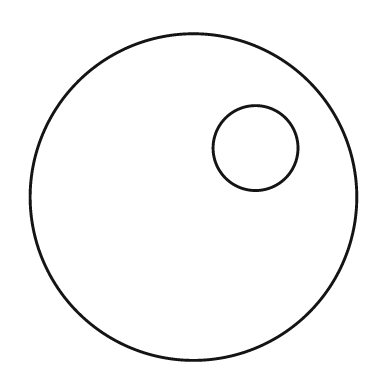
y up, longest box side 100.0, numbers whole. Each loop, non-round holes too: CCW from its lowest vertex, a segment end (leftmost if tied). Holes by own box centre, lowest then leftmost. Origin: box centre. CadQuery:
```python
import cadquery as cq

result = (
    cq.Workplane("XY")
    .moveTo(0.0, 0.0)
    .circle(50.0)
    .moveTo(19.0, 15.0)
    .circle(13.0)
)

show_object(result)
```